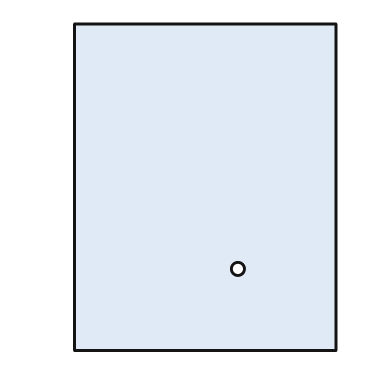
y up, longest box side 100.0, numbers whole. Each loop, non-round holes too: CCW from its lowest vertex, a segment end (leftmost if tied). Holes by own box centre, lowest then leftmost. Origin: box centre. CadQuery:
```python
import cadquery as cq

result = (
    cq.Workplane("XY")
    .moveTo(-40.0, -50.0)
    .lineTo(40.0, -50.0)
    .lineTo(40.0, 50.0)
    .lineTo(-40.0, 50.0)
    .close()
    .moveTo(10.0, -25.0)
    .circle(2.0)
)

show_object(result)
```